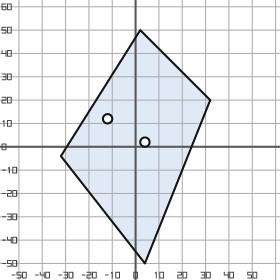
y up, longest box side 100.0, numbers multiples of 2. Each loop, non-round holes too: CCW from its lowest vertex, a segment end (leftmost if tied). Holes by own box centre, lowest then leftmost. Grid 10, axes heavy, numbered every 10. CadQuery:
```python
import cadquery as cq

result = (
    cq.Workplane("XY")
    .moveTo(4.0, -50.0)
    .lineTo(32.0, 20.0)
    .lineTo(2.0, 50.0)
    .lineTo(-32.0, -4.0)
    .close()
    .moveTo(4.0, 2.0)
    .circle(2.0)
    .moveTo(-12.0, 12.0)
    .circle(2.0)
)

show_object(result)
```